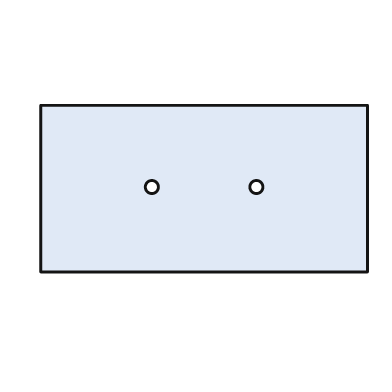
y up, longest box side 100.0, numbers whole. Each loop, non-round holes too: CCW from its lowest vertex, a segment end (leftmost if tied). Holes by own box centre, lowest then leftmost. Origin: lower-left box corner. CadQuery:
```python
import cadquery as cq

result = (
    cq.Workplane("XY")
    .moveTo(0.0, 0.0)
    .lineTo(100.0, 0.0)
    .lineTo(100.0, 51.0)
    .lineTo(0.0, 51.0)
    .close()
    .moveTo(34.0, 26.0)
    .circle(2.0)
    .moveTo(66.0, 26.0)
    .circle(2.0)
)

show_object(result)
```